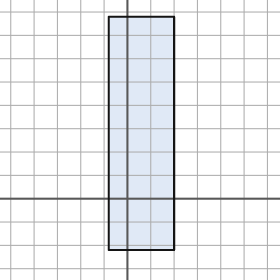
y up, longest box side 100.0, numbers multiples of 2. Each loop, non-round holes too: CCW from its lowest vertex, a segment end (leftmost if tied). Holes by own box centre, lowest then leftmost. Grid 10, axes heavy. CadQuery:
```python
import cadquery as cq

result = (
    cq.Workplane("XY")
    .moveTo(-8.0, -22.0)
    .lineTo(20.0, -22.0)
    .lineTo(20.0, 78.0)
    .lineTo(-8.0, 78.0)
    .close()
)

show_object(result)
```